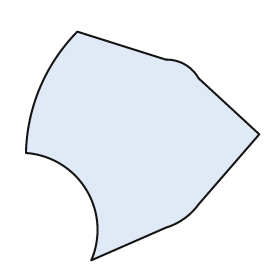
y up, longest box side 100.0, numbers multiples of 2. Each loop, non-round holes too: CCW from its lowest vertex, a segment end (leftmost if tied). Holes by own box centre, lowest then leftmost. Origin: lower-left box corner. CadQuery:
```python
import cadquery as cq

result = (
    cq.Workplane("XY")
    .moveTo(28.0, 0.0)
    .lineTo(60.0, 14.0)
    .threePointArc((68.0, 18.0), (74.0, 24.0))
    .lineTo(100.0, 54.0)
    .lineTo(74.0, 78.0)
    .threePointArc((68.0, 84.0), (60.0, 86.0))
    .lineTo(22.0, 98.0)
    .threePointArc((6.0, 74.0), (0.0, 46.0))
    .threePointArc((26.0, 30.0), (28.0, 0.0))
    .close()
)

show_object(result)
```